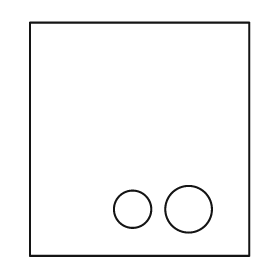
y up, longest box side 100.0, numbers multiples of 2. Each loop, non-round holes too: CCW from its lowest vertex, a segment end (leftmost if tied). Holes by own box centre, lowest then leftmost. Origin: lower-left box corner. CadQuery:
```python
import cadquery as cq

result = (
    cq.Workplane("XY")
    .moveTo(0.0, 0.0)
    .lineTo(94.0, 0.0)
    .lineTo(94.0, 100.0)
    .lineTo(0.0, 100.0)
    .close()
    .moveTo(44.0, 20.0)
    .circle(8.0)
    .moveTo(68.0, 20.0)
    .circle(10.0)
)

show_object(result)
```